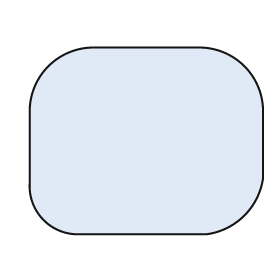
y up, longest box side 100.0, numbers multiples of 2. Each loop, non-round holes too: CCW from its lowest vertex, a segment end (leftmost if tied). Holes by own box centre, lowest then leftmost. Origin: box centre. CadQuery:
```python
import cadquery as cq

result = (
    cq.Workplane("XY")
    .moveTo(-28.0, -40.0)
    .lineTo(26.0, -40.0)
    .threePointArc((42.0, -32.0), (50.0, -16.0))
    .lineTo(50.0, 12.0)
    .threePointArc((42.0, 32.0), (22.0, 40.0))
    .lineTo(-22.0, 40.0)
    .threePointArc((-42.0, 32.0), (-50.0, 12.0))
    .lineTo(-50.0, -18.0)
    .threePointArc((-44.0, -34.0), (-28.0, -40.0))
    .close()
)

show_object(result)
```